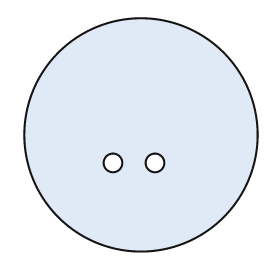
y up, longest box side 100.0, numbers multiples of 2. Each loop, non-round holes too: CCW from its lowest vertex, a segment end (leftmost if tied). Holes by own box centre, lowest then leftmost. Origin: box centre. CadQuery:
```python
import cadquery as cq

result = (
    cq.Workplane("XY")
    .moveTo(0.0, 0.0)
    .circle(50.0)
    .moveTo(-12.0, -12.0)
    .circle(4.0)
    .moveTo(6.0, -12.0)
    .circle(4.0)
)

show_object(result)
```